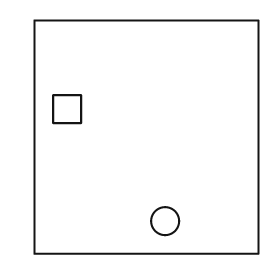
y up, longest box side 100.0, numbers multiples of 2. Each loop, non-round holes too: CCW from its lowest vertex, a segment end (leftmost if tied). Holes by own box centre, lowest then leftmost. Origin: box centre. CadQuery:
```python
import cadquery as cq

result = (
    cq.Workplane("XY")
    .moveTo(-48.0, -50.0)
    .lineTo(48.0, -50.0)
    .lineTo(48.0, 50.0)
    .lineTo(-48.0, 50.0)
    .close()
    .moveTo(8.0, -36.0)
    .circle(6.0)
    .moveTo(-40.0, 6.0)
    .lineTo(-28.0, 6.0)
    .lineTo(-28.0, 18.0)
    .lineTo(-40.0, 18.0)
    .close()
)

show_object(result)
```